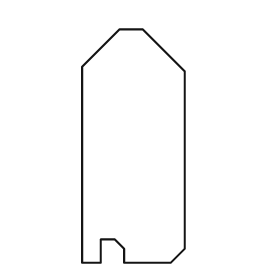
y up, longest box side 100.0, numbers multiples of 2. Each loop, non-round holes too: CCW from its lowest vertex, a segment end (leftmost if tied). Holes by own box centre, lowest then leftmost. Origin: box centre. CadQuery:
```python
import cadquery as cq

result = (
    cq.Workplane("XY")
    .moveTo(-22.0, -50.0)
    .lineTo(-14.0, -50.0)
    .lineTo(-14.0, -40.0)
    .lineTo(-8.0, -40.0)
    .lineTo(-4.0, -44.0)
    .lineTo(-4.0, -50.0)
    .lineTo(16.0, -50.0)
    .lineTo(22.0, -44.0)
    .lineTo(22.0, 32.0)
    .lineTo(4.0, 50.0)
    .lineTo(-6.0, 50.0)
    .lineTo(-22.0, 34.0)
    .close()
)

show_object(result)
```